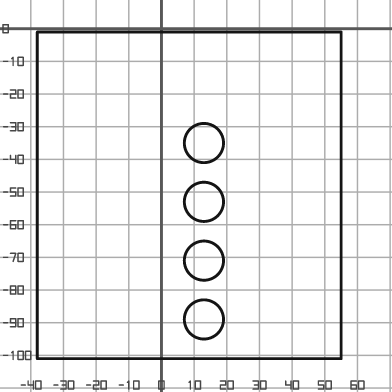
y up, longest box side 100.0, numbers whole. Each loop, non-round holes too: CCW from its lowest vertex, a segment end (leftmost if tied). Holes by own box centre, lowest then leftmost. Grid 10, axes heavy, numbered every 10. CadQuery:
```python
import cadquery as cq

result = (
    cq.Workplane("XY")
    .moveTo(-38.0, -101.0)
    .lineTo(55.0, -101.0)
    .lineTo(55.0, -1.0)
    .lineTo(-38.0, -1.0)
    .close()
    .moveTo(13.0, -89.0)
    .circle(6.0)
    .moveTo(13.0, -71.0)
    .circle(6.0)
    .moveTo(13.0, -53.0)
    .circle(6.0)
    .moveTo(13.0, -35.0)
    .circle(6.0)
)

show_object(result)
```